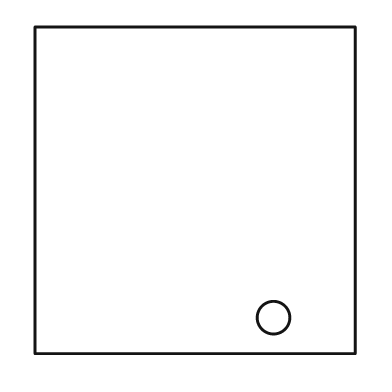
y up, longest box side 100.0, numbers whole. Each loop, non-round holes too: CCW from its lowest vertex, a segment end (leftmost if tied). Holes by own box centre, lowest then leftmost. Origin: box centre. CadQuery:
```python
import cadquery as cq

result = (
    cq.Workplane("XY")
    .moveTo(-49.0, -50.0)
    .lineTo(49.0, -50.0)
    .lineTo(49.0, 50.0)
    .lineTo(-49.0, 50.0)
    .close()
    .moveTo(24.0, -39.0)
    .circle(5.0)
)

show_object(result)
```